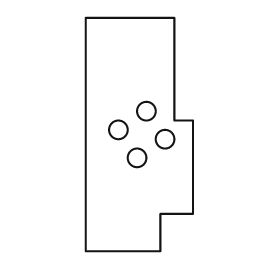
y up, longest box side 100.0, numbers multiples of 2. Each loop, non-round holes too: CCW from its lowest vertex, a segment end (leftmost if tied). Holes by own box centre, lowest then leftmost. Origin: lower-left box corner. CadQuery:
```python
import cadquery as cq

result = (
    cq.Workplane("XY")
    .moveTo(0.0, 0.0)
    .lineTo(32.0, 0.0)
    .lineTo(32.0, 16.0)
    .lineTo(46.0, 16.0)
    .lineTo(46.0, 56.0)
    .lineTo(38.0, 56.0)
    .lineTo(38.0, 100.0)
    .lineTo(0.0, 100.0)
    .close()
    .moveTo(22.0, 40.0)
    .circle(4.0)
    .moveTo(34.0, 48.0)
    .circle(4.0)
    .moveTo(14.0, 52.0)
    .circle(4.0)
    .moveTo(26.0, 60.0)
    .circle(4.0)
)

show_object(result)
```